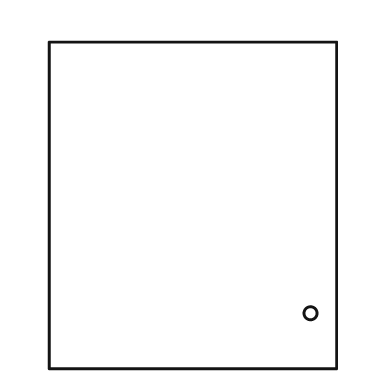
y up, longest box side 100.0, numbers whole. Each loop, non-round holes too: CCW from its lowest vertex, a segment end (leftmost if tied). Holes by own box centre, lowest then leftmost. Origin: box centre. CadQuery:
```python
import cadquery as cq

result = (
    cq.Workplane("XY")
    .moveTo(-44.0, -50.0)
    .lineTo(44.0, -50.0)
    .lineTo(44.0, 50.0)
    .lineTo(-44.0, 50.0)
    .close()
    .moveTo(36.0, -33.0)
    .circle(2.0)
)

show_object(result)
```